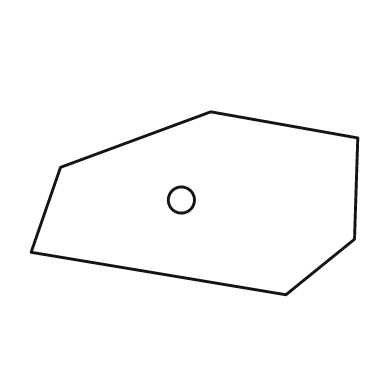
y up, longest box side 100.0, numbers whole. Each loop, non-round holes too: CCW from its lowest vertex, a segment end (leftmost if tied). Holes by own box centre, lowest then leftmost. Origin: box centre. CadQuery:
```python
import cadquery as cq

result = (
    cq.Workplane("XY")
    .moveTo(28.0, -28.0)
    .lineTo(49.0, -11.0)
    .lineTo(50.0, 20.0)
    .lineTo(5.0, 28.0)
    .lineTo(-41.0, 11.0)
    .lineTo(-50.0, -15.0)
    .close()
    .moveTo(-4.0, 1.0)
    .circle(4.0)
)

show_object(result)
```